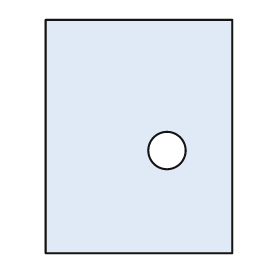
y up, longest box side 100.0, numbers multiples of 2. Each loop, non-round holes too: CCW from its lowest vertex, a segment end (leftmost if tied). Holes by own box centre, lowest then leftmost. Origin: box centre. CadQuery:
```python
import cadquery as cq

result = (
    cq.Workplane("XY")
    .moveTo(-40.0, -50.0)
    .lineTo(40.0, -50.0)
    .lineTo(40.0, 50.0)
    .lineTo(-40.0, 50.0)
    .close()
    .moveTo(12.0, -6.0)
    .circle(8.0)
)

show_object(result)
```